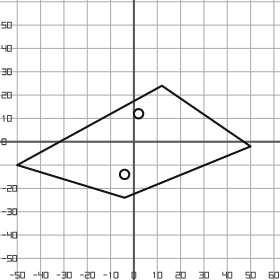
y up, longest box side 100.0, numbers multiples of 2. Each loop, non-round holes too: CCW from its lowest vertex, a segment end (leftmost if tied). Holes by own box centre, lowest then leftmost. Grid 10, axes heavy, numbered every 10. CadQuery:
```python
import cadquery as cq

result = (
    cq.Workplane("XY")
    .moveTo(-4.0, -24.0)
    .lineTo(50.0, -2.0)
    .lineTo(12.0, 24.0)
    .lineTo(-50.0, -10.0)
    .close()
    .moveTo(-4.0, -14.0)
    .circle(2.0)
    .moveTo(2.0, 12.0)
    .circle(2.0)
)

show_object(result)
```